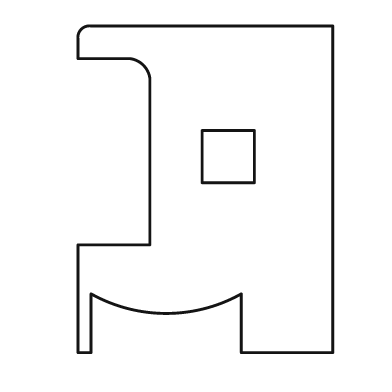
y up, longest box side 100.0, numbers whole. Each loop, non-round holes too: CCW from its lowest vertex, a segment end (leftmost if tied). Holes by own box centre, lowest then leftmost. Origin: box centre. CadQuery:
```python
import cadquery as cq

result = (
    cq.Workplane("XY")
    .moveTo(-39.0, -50.0)
    .lineTo(-35.0, -50.0)
    .lineTo(-35.0, -32.0)
    .threePointArc((-12.0, -38.0), (11.0, -32.0))
    .lineTo(11.0, -50.0)
    .lineTo(39.0, -50.0)
    .lineTo(39.0, 50.0)
    .lineTo(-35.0, 50.0)
    .threePointArc((-38.0, 49.0), (-39.0, 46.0))
    .lineTo(-39.0, 40.0)
    .lineTo(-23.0, 40.0)
    .threePointArc((-19.0, 38.0), (-17.0, 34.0))
    .lineTo(-17.0, -17.0)
    .lineTo(-39.0, -17.0)
    .close()
    .moveTo(-1.0, 2.0)
    .lineTo(15.0, 2.0)
    .lineTo(15.0, 18.0)
    .lineTo(-1.0, 18.0)
    .close()
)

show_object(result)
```